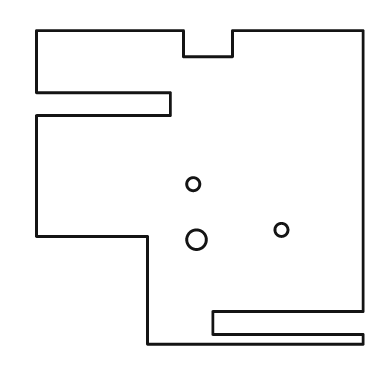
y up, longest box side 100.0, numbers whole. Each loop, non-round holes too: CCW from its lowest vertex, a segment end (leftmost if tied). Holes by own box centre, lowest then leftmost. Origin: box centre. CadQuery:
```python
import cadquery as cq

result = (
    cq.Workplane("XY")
    .moveTo(-16.0, -48.0)
    .lineTo(50.0, -48.0)
    .lineTo(50.0, -45.0)
    .lineTo(4.0, -45.0)
    .lineTo(4.0, -38.0)
    .lineTo(50.0, -38.0)
    .lineTo(50.0, 48.0)
    .lineTo(10.0, 48.0)
    .lineTo(10.0, 40.0)
    .lineTo(-5.0, 40.0)
    .lineTo(-5.0, 48.0)
    .lineTo(-50.0, 48.0)
    .lineTo(-50.0, 29.0)
    .lineTo(-9.0, 29.0)
    .lineTo(-9.0, 22.0)
    .lineTo(-50.0, 22.0)
    .lineTo(-50.0, -15.0)
    .lineTo(-16.0, -15.0)
    .close()
    .moveTo(-1.0, -16.0)
    .circle(3.0)
    .moveTo(25.0, -13.0)
    .circle(2.0)
    .moveTo(-2.0, 1.0)
    .circle(2.0)
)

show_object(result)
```